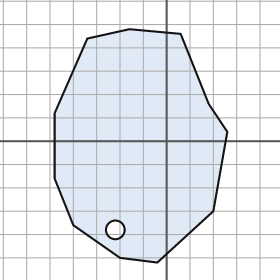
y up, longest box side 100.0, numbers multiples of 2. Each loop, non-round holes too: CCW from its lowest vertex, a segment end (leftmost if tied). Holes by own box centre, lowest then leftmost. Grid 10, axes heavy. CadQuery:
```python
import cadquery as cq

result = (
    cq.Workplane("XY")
    .moveTo(-4.0, -52.0)
    .lineTo(20.0, -30.0)
    .lineTo(26.0, 4.0)
    .lineTo(18.0, 16.0)
    .lineTo(6.0, 46.0)
    .lineTo(-16.0, 48.0)
    .lineTo(-34.0, 44.0)
    .lineTo(-48.0, 12.0)
    .lineTo(-48.0, -16.0)
    .lineTo(-40.0, -36.0)
    .lineTo(-20.0, -50.0)
    .close()
    .moveTo(-22.0, -38.0)
    .circle(4.0)
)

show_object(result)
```